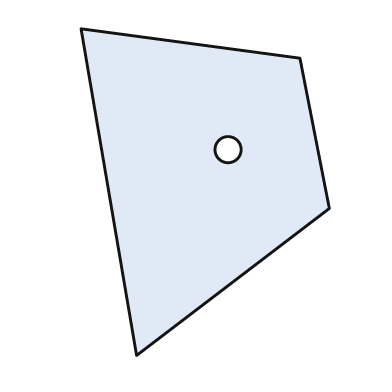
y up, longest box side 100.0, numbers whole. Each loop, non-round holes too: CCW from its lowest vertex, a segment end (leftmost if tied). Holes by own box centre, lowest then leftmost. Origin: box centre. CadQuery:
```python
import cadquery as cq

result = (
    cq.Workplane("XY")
    .moveTo(-21.0, -50.0)
    .lineTo(38.0, -5.0)
    .lineTo(29.0, 41.0)
    .lineTo(-38.0, 50.0)
    .close()
    .moveTo(7.0, 13.0)
    .circle(4.0)
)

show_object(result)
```